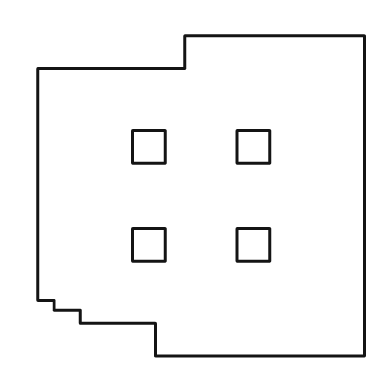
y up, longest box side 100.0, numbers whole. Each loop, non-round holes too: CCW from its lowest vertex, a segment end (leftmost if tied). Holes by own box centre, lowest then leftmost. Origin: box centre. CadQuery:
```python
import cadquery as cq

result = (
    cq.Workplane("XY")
    .moveTo(-14.0, -49.0)
    .lineTo(50.0, -49.0)
    .lineTo(50.0, 49.0)
    .lineTo(-5.0, 49.0)
    .lineTo(-5.0, 39.0)
    .lineTo(-50.0, 39.0)
    .lineTo(-50.0, -32.0)
    .lineTo(-45.0, -32.0)
    .lineTo(-45.0, -35.0)
    .lineTo(-37.0, -35.0)
    .lineTo(-37.0, -39.0)
    .lineTo(-14.0, -39.0)
    .close()
    .moveTo(-21.0, -20.0)
    .lineTo(-11.0, -20.0)
    .lineTo(-11.0, -10.0)
    .lineTo(-21.0, -10.0)
    .close()
    .moveTo(11.0, -20.0)
    .lineTo(21.0, -20.0)
    .lineTo(21.0, -10.0)
    .lineTo(11.0, -10.0)
    .close()
    .moveTo(-21.0, 10.0)
    .lineTo(-11.0, 10.0)
    .lineTo(-11.0, 20.0)
    .lineTo(-21.0, 20.0)
    .close()
    .moveTo(11.0, 10.0)
    .lineTo(21.0, 10.0)
    .lineTo(21.0, 20.0)
    .lineTo(11.0, 20.0)
    .close()
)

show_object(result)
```